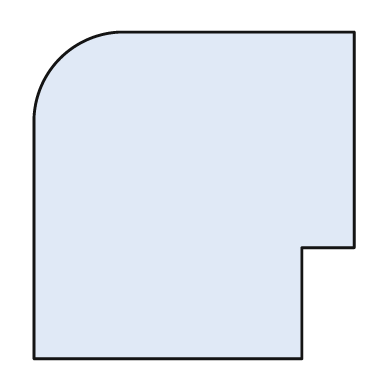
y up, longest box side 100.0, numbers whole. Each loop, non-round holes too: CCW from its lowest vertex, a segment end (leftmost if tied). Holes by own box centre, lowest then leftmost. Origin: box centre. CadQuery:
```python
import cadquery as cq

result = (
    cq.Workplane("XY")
    .moveTo(-49.0, -50.0)
    .lineTo(33.0, -50.0)
    .lineTo(33.0, -16.0)
    .lineTo(49.0, -16.0)
    .lineTo(49.0, 50.0)
    .lineTo(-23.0, 50.0)
    .threePointArc((-41.0, 42.0), (-49.0, 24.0))
    .close()
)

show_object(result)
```